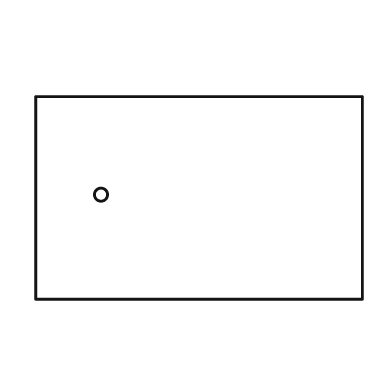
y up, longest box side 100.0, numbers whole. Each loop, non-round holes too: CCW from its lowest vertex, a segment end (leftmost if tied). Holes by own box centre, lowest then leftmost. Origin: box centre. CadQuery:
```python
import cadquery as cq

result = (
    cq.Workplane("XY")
    .moveTo(-50.0, -31.0)
    .lineTo(50.0, -31.0)
    .lineTo(50.0, 31.0)
    .lineTo(-50.0, 31.0)
    .close()
    .moveTo(-30.0, 1.0)
    .circle(2.0)
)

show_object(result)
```